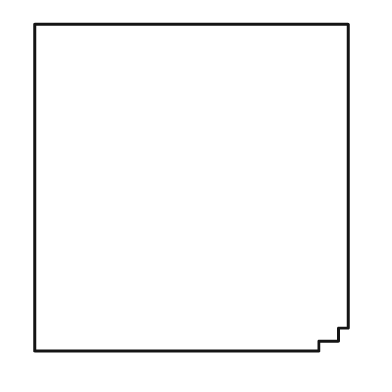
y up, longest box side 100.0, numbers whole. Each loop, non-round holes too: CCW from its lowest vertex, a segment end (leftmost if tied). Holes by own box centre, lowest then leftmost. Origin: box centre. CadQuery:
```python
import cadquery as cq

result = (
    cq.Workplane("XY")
    .moveTo(-48.0, -50.0)
    .lineTo(39.0, -50.0)
    .lineTo(39.0, -47.0)
    .lineTo(45.0, -47.0)
    .lineTo(45.0, -43.0)
    .lineTo(48.0, -43.0)
    .lineTo(48.0, 50.0)
    .lineTo(-48.0, 50.0)
    .close()
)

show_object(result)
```